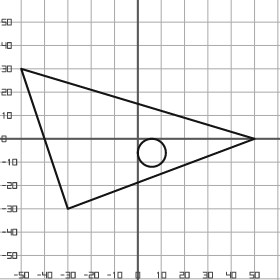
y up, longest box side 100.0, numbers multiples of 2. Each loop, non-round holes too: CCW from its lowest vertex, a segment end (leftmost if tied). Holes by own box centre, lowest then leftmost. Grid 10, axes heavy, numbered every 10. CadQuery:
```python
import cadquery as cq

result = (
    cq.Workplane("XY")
    .moveTo(-30.0, -30.0)
    .lineTo(50.0, 0.0)
    .lineTo(-50.0, 30.0)
    .close()
    .moveTo(6.0, -6.0)
    .circle(6.0)
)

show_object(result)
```